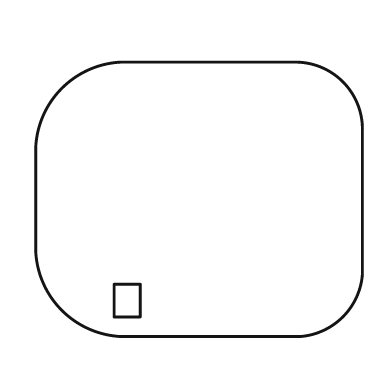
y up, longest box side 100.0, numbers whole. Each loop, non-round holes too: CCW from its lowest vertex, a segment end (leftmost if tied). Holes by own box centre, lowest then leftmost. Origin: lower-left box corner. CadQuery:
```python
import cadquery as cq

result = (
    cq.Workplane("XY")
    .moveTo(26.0, 0.0)
    .lineTo(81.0, 0.0)
    .threePointArc((94.0, 6.0), (100.0, 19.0))
    .lineTo(100.0, 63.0)
    .threePointArc((94.0, 78.0), (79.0, 84.0))
    .lineTo(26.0, 84.0)
    .threePointArc((8.0, 76.0), (0.0, 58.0))
    .lineTo(0.0, 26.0)
    .threePointArc((8.0, 8.0), (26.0, 0.0))
    .close()
    .moveTo(24.0, 6.0)
    .lineTo(32.0, 6.0)
    .lineTo(32.0, 16.0)
    .lineTo(24.0, 16.0)
    .close()
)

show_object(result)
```